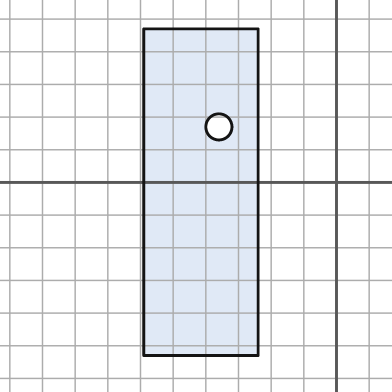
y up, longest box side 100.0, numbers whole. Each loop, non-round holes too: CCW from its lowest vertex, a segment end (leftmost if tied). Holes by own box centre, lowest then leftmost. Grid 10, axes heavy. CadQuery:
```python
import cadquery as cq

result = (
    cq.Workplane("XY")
    .moveTo(-59.0, -53.0)
    .lineTo(-24.0, -53.0)
    .lineTo(-24.0, 47.0)
    .lineTo(-59.0, 47.0)
    .close()
    .moveTo(-36.0, 17.0)
    .circle(4.0)
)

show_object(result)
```